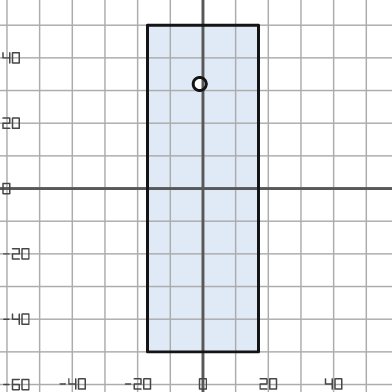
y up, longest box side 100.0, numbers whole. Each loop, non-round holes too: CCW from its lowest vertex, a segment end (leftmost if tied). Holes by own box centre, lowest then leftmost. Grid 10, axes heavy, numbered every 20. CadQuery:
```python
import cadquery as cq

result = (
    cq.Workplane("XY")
    .moveTo(-17.0, -50.0)
    .lineTo(17.0, -50.0)
    .lineTo(17.0, 50.0)
    .lineTo(-17.0, 50.0)
    .close()
    .moveTo(-1.0, 32.0)
    .circle(2.0)
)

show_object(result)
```